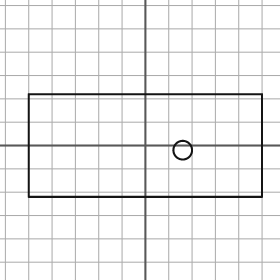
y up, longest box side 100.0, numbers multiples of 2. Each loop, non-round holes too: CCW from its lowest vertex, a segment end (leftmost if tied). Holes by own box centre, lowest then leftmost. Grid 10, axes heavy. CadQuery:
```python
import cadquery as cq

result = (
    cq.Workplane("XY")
    .moveTo(-50.0, -22.0)
    .lineTo(50.0, -22.0)
    .lineTo(50.0, 22.0)
    .lineTo(-50.0, 22.0)
    .close()
    .moveTo(16.0, -2.0)
    .circle(4.0)
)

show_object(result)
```